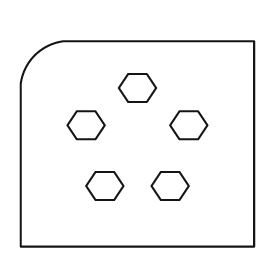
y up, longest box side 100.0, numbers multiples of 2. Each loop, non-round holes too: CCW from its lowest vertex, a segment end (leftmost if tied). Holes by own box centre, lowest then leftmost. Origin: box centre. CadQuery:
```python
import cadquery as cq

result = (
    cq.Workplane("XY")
    .moveTo(-50.0, -44.0)
    .lineTo(50.0, -44.0)
    .lineTo(50.0, 44.0)
    .lineTo(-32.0, 44.0)
    .threePointArc((-44.0, 38.0), (-50.0, 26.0))
    .close()
    .moveTo(-18.0, -24.0)
    .lineTo(-10.0, -24.0)
    .lineTo(-6.0, -18.0)
    .lineTo(-10.0, -12.0)
    .lineTo(-18.0, -12.0)
    .lineTo(-22.0, -18.0)
    .close()
    .moveTo(10.0, -24.0)
    .lineTo(18.0, -24.0)
    .lineTo(22.0, -18.0)
    .lineTo(18.0, -12.0)
    .lineTo(10.0, -12.0)
    .lineTo(6.0, -18.0)
    .close()
    .moveTo(-26.0, 2.0)
    .lineTo(-18.0, 2.0)
    .lineTo(-14.0, 8.0)
    .lineTo(-18.0, 14.0)
    .lineTo(-26.0, 14.0)
    .lineTo(-30.0, 8.0)
    .close()
    .moveTo(18.0, 2.0)
    .lineTo(26.0, 2.0)
    .lineTo(30.0, 8.0)
    .lineTo(26.0, 14.0)
    .lineTo(18.0, 14.0)
    .lineTo(14.0, 8.0)
    .close()
    .moveTo(-4.0, 18.0)
    .lineTo(4.0, 18.0)
    .lineTo(8.0, 24.0)
    .lineTo(4.0, 30.0)
    .lineTo(-4.0, 30.0)
    .lineTo(-8.0, 24.0)
    .close()
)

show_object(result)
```